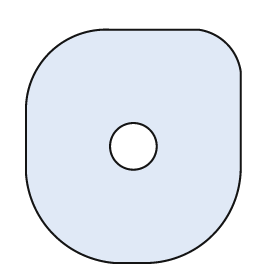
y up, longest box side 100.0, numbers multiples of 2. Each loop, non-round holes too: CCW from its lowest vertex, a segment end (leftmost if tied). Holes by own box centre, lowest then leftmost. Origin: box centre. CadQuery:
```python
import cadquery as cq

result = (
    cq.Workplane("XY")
    .moveTo(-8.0, -50.0)
    .lineTo(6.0, -50.0)
    .threePointArc((34.0, -38.0), (46.0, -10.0))
    .lineTo(46.0, 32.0)
    .threePointArc((40.0, 44.0), (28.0, 50.0))
    .lineTo(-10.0, 50.0)
    .threePointArc((-36.0, 40.0), (-46.0, 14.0))
    .lineTo(-46.0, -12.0)
    .threePointArc((-34.0, -38.0), (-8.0, -50.0))
    .close()
    .moveTo(0.0, 0.0)
    .circle(10.0)
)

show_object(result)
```